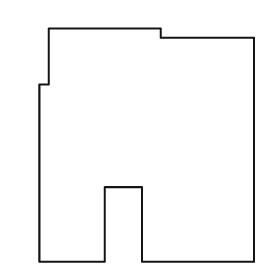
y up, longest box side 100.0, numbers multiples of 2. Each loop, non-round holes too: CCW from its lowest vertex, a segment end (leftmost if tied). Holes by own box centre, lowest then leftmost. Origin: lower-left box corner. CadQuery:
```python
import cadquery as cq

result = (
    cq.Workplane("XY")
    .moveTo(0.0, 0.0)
    .lineTo(28.0, 0.0)
    .lineTo(28.0, 32.0)
    .lineTo(44.0, 32.0)
    .lineTo(44.0, 0.0)
    .lineTo(92.0, 0.0)
    .lineTo(92.0, 96.0)
    .lineTo(52.0, 96.0)
    .lineTo(52.0, 100.0)
    .lineTo(4.0, 100.0)
    .lineTo(4.0, 76.0)
    .lineTo(0.0, 76.0)
    .close()
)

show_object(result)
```